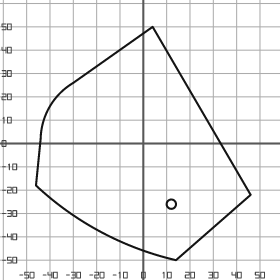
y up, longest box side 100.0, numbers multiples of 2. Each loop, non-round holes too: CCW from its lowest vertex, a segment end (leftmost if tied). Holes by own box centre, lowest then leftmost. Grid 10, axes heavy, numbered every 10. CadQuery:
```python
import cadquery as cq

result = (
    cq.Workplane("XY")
    .moveTo(14.0, -50.0)
    .lineTo(46.0, -22.0)
    .lineTo(4.0, 50.0)
    .lineTo(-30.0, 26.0)
    .threePointArc((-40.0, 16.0), (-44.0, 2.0))
    .lineTo(-46.0, -18.0)
    .threePointArc((-18.0, -38.0), (14.0, -50.0))
    .close()
    .moveTo(12.0, -26.0)
    .circle(2.0)
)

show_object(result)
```